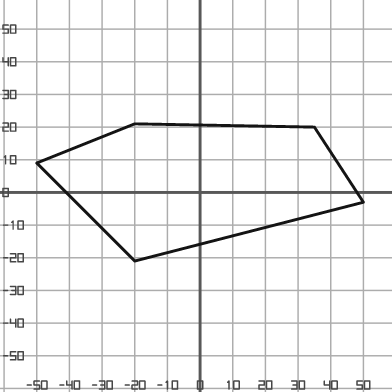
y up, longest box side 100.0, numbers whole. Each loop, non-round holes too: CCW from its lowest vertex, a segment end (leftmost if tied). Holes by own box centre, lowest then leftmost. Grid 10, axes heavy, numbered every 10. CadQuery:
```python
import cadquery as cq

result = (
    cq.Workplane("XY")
    .moveTo(-20.0, -21.0)
    .lineTo(50.0, -3.0)
    .lineTo(35.0, 20.0)
    .lineTo(-20.0, 21.0)
    .lineTo(-50.0, 9.0)
    .close()
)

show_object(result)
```